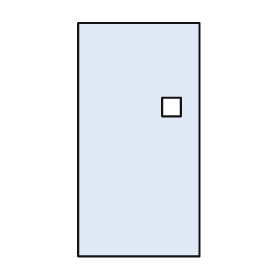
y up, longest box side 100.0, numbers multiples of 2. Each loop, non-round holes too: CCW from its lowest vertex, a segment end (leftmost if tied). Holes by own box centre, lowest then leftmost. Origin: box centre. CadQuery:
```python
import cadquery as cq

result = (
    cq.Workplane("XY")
    .moveTo(-26.0, -50.0)
    .lineTo(26.0, -50.0)
    .lineTo(26.0, 50.0)
    .lineTo(-26.0, 50.0)
    .close()
    .moveTo(10.0, 10.0)
    .lineTo(18.0, 10.0)
    .lineTo(18.0, 18.0)
    .lineTo(10.0, 18.0)
    .close()
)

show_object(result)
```